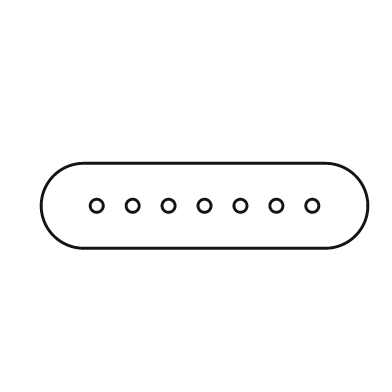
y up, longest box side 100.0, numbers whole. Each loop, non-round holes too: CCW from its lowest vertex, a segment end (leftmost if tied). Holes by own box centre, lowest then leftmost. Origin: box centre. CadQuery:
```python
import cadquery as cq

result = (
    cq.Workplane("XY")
    .moveTo(-37.0, -13.0)
    .lineTo(37.0, -13.0)
    .threePointArc((50.0, 0.0), (37.0, 13.0))
    .lineTo(-37.0, 13.0)
    .threePointArc((-50.0, 0.0), (-37.0, -13.0))
    .close()
    .moveTo(-33.0, 0.0)
    .circle(2.0)
    .moveTo(-22.0, 0.0)
    .circle(2.0)
    .moveTo(-11.0, 0.0)
    .circle(2.0)
    .moveTo(0.0, 0.0)
    .circle(2.0)
    .moveTo(11.0, 0.0)
    .circle(2.0)
    .moveTo(22.0, 0.0)
    .circle(2.0)
    .moveTo(33.0, 0.0)
    .circle(2.0)
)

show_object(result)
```